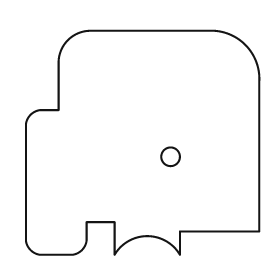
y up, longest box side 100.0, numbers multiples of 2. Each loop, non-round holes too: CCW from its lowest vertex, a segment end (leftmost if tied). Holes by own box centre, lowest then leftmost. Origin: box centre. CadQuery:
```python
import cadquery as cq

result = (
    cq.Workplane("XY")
    .moveTo(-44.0, -48.0)
    .lineTo(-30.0, -48.0)
    .threePointArc((-26.0, -46.0), (-24.0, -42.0))
    .lineTo(-24.0, -34.0)
    .lineTo(-12.0, -34.0)
    .lineTo(-12.0, -48.0)
    .threePointArc((2.0, -40.0), (16.0, -48.0))
    .lineTo(16.0, -38.0)
    .lineTo(50.0, -38.0)
    .lineTo(50.0, 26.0)
    .threePointArc((44.0, 42.0), (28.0, 48.0))
    .lineTo(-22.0, 48.0)
    .threePointArc((-32.0, 44.0), (-36.0, 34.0))
    .lineTo(-36.0, 14.0)
    .lineTo(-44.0, 14.0)
    .threePointArc((-48.0, 12.0), (-50.0, 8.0))
    .lineTo(-50.0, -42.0)
    .threePointArc((-48.0, -46.0), (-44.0, -48.0))
    .close()
    .moveTo(12.0, -6.0)
    .circle(4.0)
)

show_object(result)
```